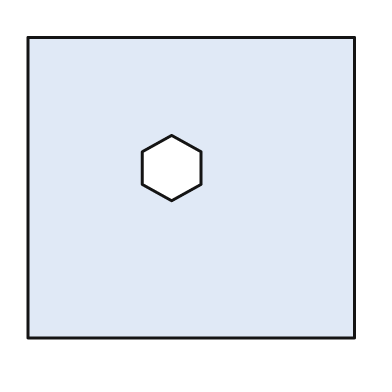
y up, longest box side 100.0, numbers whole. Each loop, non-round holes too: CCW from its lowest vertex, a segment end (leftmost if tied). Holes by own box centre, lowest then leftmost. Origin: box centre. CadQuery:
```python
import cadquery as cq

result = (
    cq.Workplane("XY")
    .moveTo(-50.0, -46.0)
    .lineTo(50.0, -46.0)
    .lineTo(50.0, 46.0)
    .lineTo(-50.0, 46.0)
    .close()
    .moveTo(-6.0, -4.0)
    .lineTo(3.0, 1.0)
    .lineTo(3.0, 11.0)
    .lineTo(-6.0, 16.0)
    .lineTo(-15.0, 11.0)
    .lineTo(-15.0, 1.0)
    .close()
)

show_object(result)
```